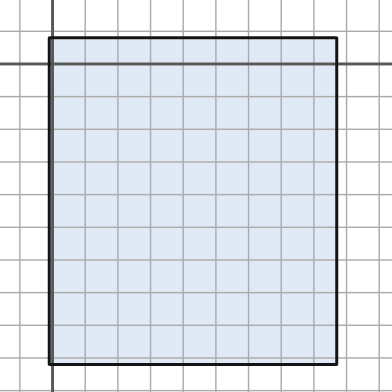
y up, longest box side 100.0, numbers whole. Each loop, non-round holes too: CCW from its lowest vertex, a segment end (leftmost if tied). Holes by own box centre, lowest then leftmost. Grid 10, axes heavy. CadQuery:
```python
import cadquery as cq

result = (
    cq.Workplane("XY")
    .moveTo(-1.0, -92.0)
    .lineTo(87.0, -92.0)
    .lineTo(87.0, 8.0)
    .lineTo(-1.0, 8.0)
    .close()
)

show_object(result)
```